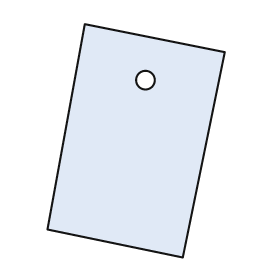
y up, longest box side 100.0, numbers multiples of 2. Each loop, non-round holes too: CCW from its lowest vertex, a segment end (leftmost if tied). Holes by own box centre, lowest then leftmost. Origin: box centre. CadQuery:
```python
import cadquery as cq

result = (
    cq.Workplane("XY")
    .moveTo(20.0, -50.0)
    .lineTo(38.0, 38.0)
    .lineTo(-22.0, 50.0)
    .lineTo(-38.0, -38.0)
    .close()
    .moveTo(4.0, 26.0)
    .circle(4.0)
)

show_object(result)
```